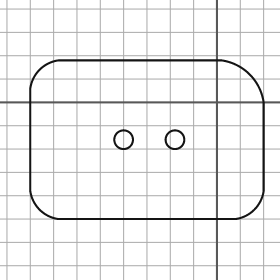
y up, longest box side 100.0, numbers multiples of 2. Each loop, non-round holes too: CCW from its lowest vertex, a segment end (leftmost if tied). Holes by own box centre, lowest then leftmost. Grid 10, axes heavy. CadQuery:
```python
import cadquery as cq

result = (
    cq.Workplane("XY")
    .moveTo(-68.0, -50.0)
    .lineTo(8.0, -50.0)
    .threePointArc((16.0, -46.0), (20.0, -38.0))
    .lineTo(20.0, 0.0)
    .threePointArc((14.0, 12.0), (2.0, 18.0))
    .lineTo(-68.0, 18.0)
    .threePointArc((-76.0, 14.0), (-80.0, 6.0))
    .lineTo(-80.0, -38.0)
    .threePointArc((-76.0, -46.0), (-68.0, -50.0))
    .close()
    .moveTo(-40.0, -16.0)
    .circle(4.0)
    .moveTo(-18.0, -16.0)
    .circle(4.0)
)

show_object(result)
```